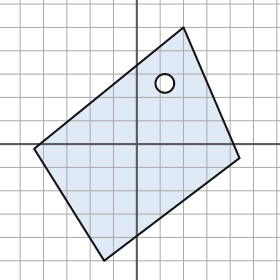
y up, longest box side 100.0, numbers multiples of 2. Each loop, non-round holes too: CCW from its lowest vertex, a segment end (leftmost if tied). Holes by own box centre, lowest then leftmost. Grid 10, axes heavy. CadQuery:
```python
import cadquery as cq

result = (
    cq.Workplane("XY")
    .moveTo(-14.0, -50.0)
    .lineTo(44.0, -6.0)
    .lineTo(20.0, 50.0)
    .lineTo(-44.0, -2.0)
    .close()
    .moveTo(12.0, 26.0)
    .circle(4.0)
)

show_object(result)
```